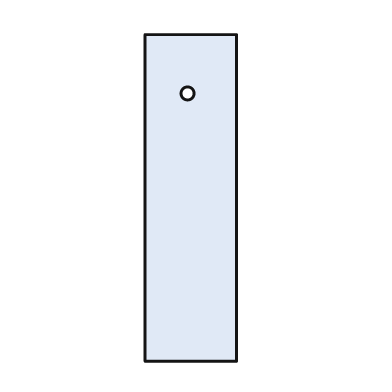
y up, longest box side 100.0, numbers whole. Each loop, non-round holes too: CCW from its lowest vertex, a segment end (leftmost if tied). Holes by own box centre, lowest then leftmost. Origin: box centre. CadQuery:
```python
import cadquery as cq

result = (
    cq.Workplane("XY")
    .moveTo(-14.0, -50.0)
    .lineTo(14.0, -50.0)
    .lineTo(14.0, 50.0)
    .lineTo(-14.0, 50.0)
    .close()
    .moveTo(-1.0, 32.0)
    .circle(2.0)
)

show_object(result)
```